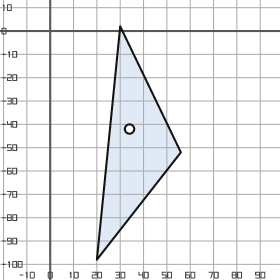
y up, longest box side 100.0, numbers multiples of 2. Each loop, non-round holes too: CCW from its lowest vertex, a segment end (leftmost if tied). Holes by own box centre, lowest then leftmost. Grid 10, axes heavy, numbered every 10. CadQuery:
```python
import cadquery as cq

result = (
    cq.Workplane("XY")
    .moveTo(20.0, -98.0)
    .lineTo(56.0, -52.0)
    .lineTo(30.0, 2.0)
    .close()
    .moveTo(34.0, -42.0)
    .circle(2.0)
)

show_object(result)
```